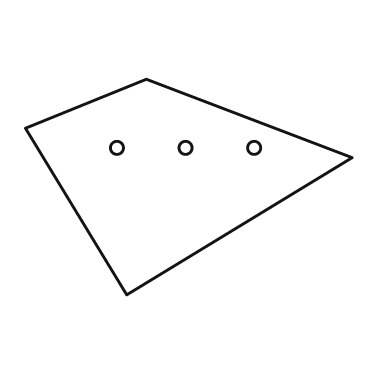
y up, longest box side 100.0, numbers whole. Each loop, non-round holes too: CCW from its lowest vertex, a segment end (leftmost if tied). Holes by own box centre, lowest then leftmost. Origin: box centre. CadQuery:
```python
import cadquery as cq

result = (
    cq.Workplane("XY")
    .moveTo(-19.0, -33.0)
    .lineTo(50.0, 9.0)
    .lineTo(-13.0, 33.0)
    .lineTo(-50.0, 18.0)
    .close()
    .moveTo(-22.0, 12.0)
    .circle(2.0)
    .moveTo(-1.0, 12.0)
    .circle(2.0)
    .moveTo(20.0, 12.0)
    .circle(2.0)
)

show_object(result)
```